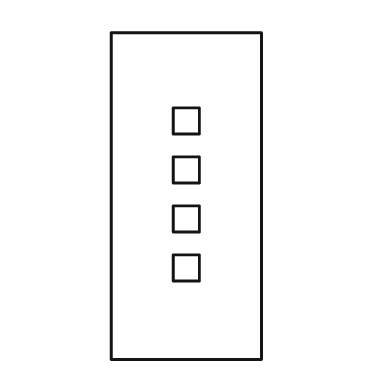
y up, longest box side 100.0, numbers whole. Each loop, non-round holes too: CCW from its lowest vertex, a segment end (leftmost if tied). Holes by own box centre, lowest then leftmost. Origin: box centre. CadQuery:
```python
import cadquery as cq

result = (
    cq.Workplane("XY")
    .moveTo(-23.0, -50.0)
    .lineTo(23.0, -50.0)
    .lineTo(23.0, 50.0)
    .lineTo(-23.0, 50.0)
    .close()
    .moveTo(-4.0, -26.0)
    .lineTo(4.0, -26.0)
    .lineTo(4.0, -18.0)
    .lineTo(-4.0, -18.0)
    .close()
    .moveTo(-4.0, -11.0)
    .lineTo(4.0, -11.0)
    .lineTo(4.0, -3.0)
    .lineTo(-4.0, -3.0)
    .close()
    .moveTo(-4.0, 4.0)
    .lineTo(4.0, 4.0)
    .lineTo(4.0, 12.0)
    .lineTo(-4.0, 12.0)
    .close()
    .moveTo(-4.0, 19.0)
    .lineTo(4.0, 19.0)
    .lineTo(4.0, 27.0)
    .lineTo(-4.0, 27.0)
    .close()
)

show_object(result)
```